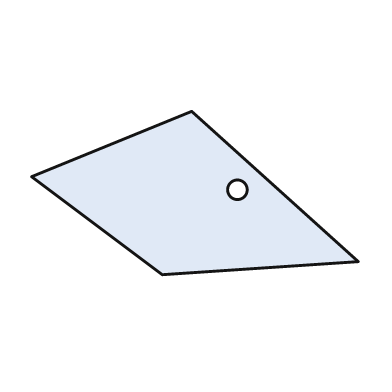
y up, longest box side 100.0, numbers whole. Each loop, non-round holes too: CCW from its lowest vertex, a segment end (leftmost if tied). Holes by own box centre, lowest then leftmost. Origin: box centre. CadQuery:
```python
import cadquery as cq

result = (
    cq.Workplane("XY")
    .moveTo(-10.0, -25.0)
    .lineTo(50.0, -21.0)
    .lineTo(-1.0, 25.0)
    .lineTo(-50.0, 5.0)
    .close()
    .moveTo(13.0, 1.0)
    .circle(3.0)
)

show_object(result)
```